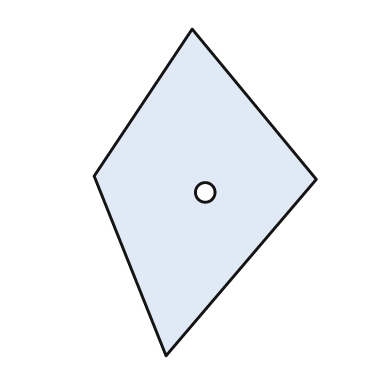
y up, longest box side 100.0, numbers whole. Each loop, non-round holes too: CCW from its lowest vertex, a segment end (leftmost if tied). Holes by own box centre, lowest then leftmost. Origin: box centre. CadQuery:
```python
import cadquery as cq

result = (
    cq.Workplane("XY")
    .moveTo(-12.0, -50.0)
    .lineTo(34.0, 4.0)
    .lineTo(-4.0, 50.0)
    .lineTo(-34.0, 5.0)
    .close()
    .moveTo(0.0, 0.0)
    .circle(3.0)
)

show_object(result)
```